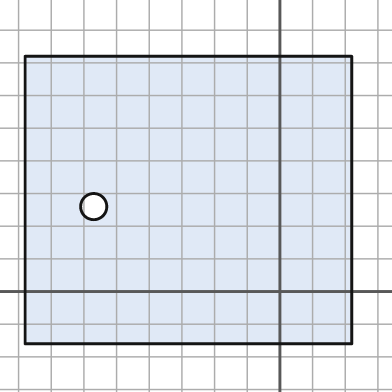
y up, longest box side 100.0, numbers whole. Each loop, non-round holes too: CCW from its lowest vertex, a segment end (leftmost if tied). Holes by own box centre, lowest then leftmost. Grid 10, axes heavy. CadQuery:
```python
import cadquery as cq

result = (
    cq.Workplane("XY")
    .moveTo(-78.0, -16.0)
    .lineTo(22.0, -16.0)
    .lineTo(22.0, 72.0)
    .lineTo(-78.0, 72.0)
    .close()
    .moveTo(-57.0, 26.0)
    .circle(4.0)
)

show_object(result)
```